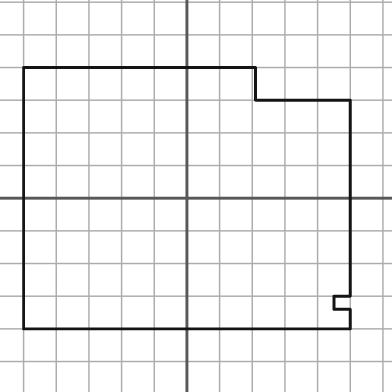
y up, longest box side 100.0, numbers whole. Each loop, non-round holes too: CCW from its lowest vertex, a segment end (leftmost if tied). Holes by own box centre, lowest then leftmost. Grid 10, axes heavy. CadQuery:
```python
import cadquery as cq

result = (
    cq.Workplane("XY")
    .moveTo(-50.0, -40.0)
    .lineTo(50.0, -40.0)
    .lineTo(50.0, -34.0)
    .lineTo(45.0, -34.0)
    .lineTo(45.0, -30.0)
    .lineTo(50.0, -30.0)
    .lineTo(50.0, 30.0)
    .lineTo(21.0, 30.0)
    .lineTo(21.0, 40.0)
    .lineTo(-50.0, 40.0)
    .close()
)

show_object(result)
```